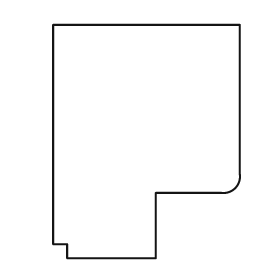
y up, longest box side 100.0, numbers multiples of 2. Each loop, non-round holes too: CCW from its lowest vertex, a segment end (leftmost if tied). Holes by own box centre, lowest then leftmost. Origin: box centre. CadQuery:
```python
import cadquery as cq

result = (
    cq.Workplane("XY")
    .moveTo(-34.0, -50.0)
    .lineTo(4.0, -50.0)
    .lineTo(4.0, -22.0)
    .lineTo(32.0, -22.0)
    .threePointArc((38.0, -20.0), (40.0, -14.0))
    .lineTo(40.0, 50.0)
    .lineTo(-40.0, 50.0)
    .lineTo(-40.0, -44.0)
    .lineTo(-34.0, -44.0)
    .close()
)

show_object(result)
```